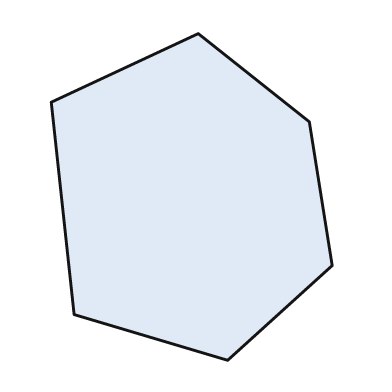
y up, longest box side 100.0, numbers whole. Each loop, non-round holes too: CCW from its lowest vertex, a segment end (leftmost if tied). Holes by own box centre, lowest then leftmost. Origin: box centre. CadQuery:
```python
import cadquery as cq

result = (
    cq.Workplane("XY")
    .moveTo(11.0, -50.0)
    .lineTo(43.0, -21.0)
    .lineTo(36.0, 23.0)
    .lineTo(2.0, 50.0)
    .lineTo(-43.0, 29.0)
    .lineTo(-36.0, -36.0)
    .close()
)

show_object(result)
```